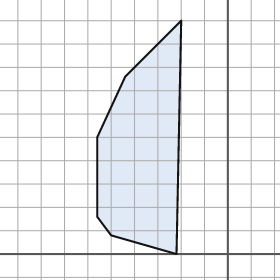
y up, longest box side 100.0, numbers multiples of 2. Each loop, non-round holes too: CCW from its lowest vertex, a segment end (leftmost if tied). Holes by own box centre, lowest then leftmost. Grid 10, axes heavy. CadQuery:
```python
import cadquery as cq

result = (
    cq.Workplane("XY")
    .moveTo(-22.0, 0.0)
    .lineTo(-20.0, 100.0)
    .lineTo(-44.0, 76.0)
    .lineTo(-56.0, 50.0)
    .lineTo(-56.0, 16.0)
    .lineTo(-50.0, 8.0)
    .close()
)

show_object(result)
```